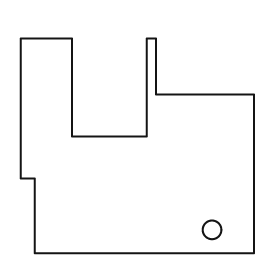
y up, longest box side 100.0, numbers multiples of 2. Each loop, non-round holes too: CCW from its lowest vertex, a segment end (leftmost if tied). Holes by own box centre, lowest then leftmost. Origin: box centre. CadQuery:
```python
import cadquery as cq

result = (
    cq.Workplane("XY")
    .moveTo(-44.0, -46.0)
    .lineTo(50.0, -46.0)
    .lineTo(50.0, 22.0)
    .lineTo(8.0, 22.0)
    .lineTo(8.0, 46.0)
    .lineTo(4.0, 46.0)
    .lineTo(4.0, 4.0)
    .lineTo(-28.0, 4.0)
    .lineTo(-28.0, 46.0)
    .lineTo(-50.0, 46.0)
    .lineTo(-50.0, -14.0)
    .lineTo(-44.0, -14.0)
    .close()
    .moveTo(32.0, -36.0)
    .circle(4.0)
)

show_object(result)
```